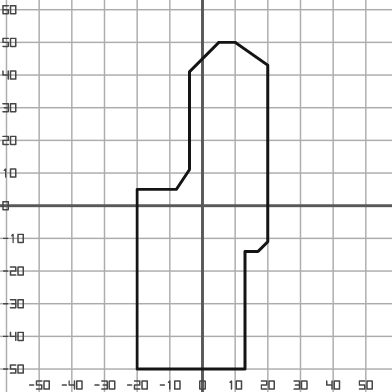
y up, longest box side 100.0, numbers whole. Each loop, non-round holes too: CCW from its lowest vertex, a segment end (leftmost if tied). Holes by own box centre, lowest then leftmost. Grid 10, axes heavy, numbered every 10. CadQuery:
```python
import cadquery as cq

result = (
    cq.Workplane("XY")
    .moveTo(-20.0, -50.0)
    .lineTo(13.0, -50.0)
    .lineTo(13.0, -14.0)
    .lineTo(17.0, -14.0)
    .lineTo(20.0, -11.0)
    .lineTo(20.0, 43.0)
    .lineTo(10.0, 50.0)
    .lineTo(5.0, 50.0)
    .lineTo(-4.0, 41.0)
    .lineTo(-4.0, 11.0)
    .lineTo(-8.0, 5.0)
    .lineTo(-20.0, 5.0)
    .close()
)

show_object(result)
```